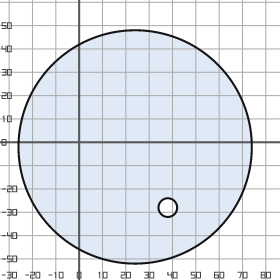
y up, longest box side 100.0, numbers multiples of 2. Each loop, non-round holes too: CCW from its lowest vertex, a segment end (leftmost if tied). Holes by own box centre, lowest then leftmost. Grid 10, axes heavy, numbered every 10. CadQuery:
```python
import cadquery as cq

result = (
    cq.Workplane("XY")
    .moveTo(24.0, -2.0)
    .circle(50.0)
    .moveTo(38.0, -28.0)
    .circle(4.0)
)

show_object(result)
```